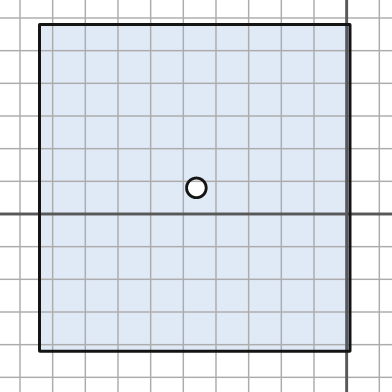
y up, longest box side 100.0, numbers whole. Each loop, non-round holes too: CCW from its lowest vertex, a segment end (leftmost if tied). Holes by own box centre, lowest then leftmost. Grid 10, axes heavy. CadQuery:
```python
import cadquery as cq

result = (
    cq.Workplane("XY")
    .moveTo(-94.0, -42.0)
    .lineTo(1.0, -42.0)
    .lineTo(1.0, 58.0)
    .lineTo(-94.0, 58.0)
    .close()
    .moveTo(-46.0, 8.0)
    .circle(3.0)
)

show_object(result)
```